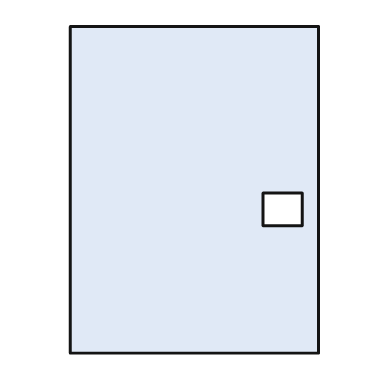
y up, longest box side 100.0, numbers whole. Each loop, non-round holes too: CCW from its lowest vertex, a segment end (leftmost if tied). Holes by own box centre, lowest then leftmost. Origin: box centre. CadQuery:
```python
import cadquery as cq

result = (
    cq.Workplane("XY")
    .moveTo(-38.0, -50.0)
    .lineTo(38.0, -50.0)
    .lineTo(38.0, 50.0)
    .lineTo(-38.0, 50.0)
    .close()
    .moveTo(21.0, -11.0)
    .lineTo(33.0, -11.0)
    .lineTo(33.0, -1.0)
    .lineTo(21.0, -1.0)
    .close()
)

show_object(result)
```